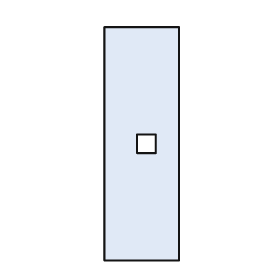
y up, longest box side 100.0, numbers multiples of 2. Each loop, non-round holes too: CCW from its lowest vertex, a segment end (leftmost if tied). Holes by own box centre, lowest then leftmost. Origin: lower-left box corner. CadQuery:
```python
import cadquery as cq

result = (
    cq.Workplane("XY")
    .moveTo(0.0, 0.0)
    .lineTo(32.0, 0.0)
    .lineTo(32.0, 100.0)
    .lineTo(0.0, 100.0)
    .close()
    .moveTo(14.0, 46.0)
    .lineTo(22.0, 46.0)
    .lineTo(22.0, 54.0)
    .lineTo(14.0, 54.0)
    .close()
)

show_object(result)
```